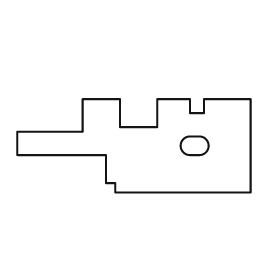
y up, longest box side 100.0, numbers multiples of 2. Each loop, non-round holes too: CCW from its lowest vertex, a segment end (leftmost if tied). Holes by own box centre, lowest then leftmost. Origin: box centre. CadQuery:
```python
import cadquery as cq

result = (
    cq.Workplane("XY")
    .moveTo(-8.0, -20.0)
    .lineTo(50.0, -20.0)
    .lineTo(50.0, 20.0)
    .lineTo(30.0, 20.0)
    .lineTo(30.0, 14.0)
    .lineTo(24.0, 14.0)
    .lineTo(24.0, 20.0)
    .lineTo(10.0, 20.0)
    .lineTo(10.0, 8.0)
    .lineTo(-6.0, 8.0)
    .lineTo(-6.0, 20.0)
    .lineTo(-22.0, 20.0)
    .lineTo(-22.0, 6.0)
    .lineTo(-50.0, 6.0)
    .lineTo(-50.0, -4.0)
    .lineTo(-12.0, -4.0)
    .lineTo(-12.0, -16.0)
    .lineTo(-8.0, -16.0)
    .close()
    .moveTo(24.0, -4.0)
    .lineTo(28.0, -4.0)
    .threePointArc((32.0, 0.0), (28.0, 4.0))
    .lineTo(24.0, 4.0)
    .threePointArc((20.0, 0.0), (24.0, -4.0))
    .close()
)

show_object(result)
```